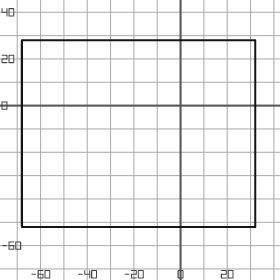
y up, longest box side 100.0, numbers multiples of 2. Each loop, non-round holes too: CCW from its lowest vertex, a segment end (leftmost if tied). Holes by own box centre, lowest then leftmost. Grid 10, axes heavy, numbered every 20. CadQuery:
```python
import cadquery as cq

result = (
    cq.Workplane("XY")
    .moveTo(-68.0, -52.0)
    .lineTo(32.0, -52.0)
    .lineTo(32.0, 28.0)
    .lineTo(-68.0, 28.0)
    .close()
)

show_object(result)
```